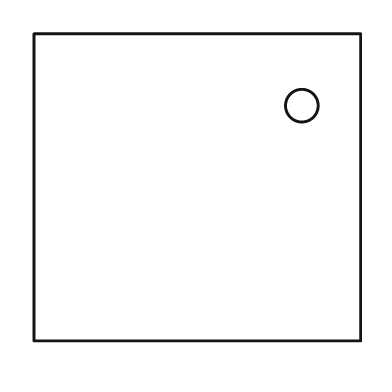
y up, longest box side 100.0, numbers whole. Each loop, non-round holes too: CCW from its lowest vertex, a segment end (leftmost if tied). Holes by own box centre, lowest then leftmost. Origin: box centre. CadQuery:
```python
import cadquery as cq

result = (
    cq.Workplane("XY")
    .moveTo(-50.0, -47.0)
    .lineTo(50.0, -47.0)
    .lineTo(50.0, 47.0)
    .lineTo(-50.0, 47.0)
    .close()
    .moveTo(32.0, 25.0)
    .circle(5.0)
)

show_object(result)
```